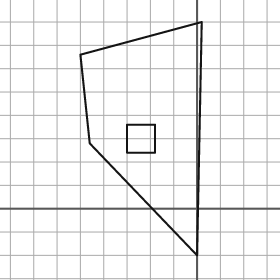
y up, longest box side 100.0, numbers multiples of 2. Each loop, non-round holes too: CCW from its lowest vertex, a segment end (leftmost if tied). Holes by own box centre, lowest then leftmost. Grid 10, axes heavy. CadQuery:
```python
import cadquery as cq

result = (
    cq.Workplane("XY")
    .moveTo(0.0, -20.0)
    .lineTo(2.0, 80.0)
    .lineTo(-50.0, 66.0)
    .lineTo(-46.0, 28.0)
    .close()
    .moveTo(-30.0, 24.0)
    .lineTo(-18.0, 24.0)
    .lineTo(-18.0, 36.0)
    .lineTo(-30.0, 36.0)
    .close()
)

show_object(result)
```